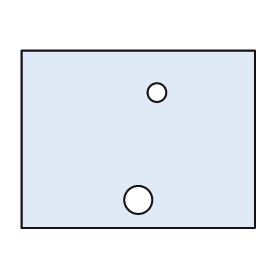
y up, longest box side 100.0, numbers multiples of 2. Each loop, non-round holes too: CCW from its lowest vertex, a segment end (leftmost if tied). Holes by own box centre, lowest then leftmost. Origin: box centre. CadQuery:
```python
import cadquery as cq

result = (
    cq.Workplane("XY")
    .moveTo(-50.0, -38.0)
    .lineTo(50.0, -38.0)
    .lineTo(50.0, 38.0)
    .lineTo(-50.0, 38.0)
    .close()
    .moveTo(0.0, -26.0)
    .circle(6.0)
    .moveTo(8.0, 20.0)
    .circle(4.0)
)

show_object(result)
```